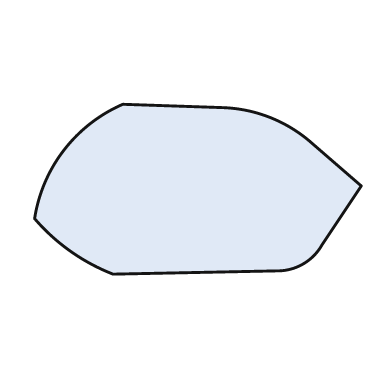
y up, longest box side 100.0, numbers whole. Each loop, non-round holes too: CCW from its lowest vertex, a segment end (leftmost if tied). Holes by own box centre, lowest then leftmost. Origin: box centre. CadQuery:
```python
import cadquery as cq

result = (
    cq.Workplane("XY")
    .moveTo(-26.0, -26.0)
    .lineTo(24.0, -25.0)
    .threePointArc((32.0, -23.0), (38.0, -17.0))
    .lineTo(50.0, 1.0)
    .lineTo(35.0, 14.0)
    .threePointArc((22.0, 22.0), (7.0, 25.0))
    .lineTo(-23.0, 26.0)
    .threePointArc((-41.0, 12.0), (-50.0, -9.0))
    .threePointArc((-39.0, -19.0), (-26.0, -26.0))
    .close()
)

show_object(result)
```